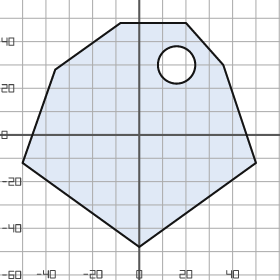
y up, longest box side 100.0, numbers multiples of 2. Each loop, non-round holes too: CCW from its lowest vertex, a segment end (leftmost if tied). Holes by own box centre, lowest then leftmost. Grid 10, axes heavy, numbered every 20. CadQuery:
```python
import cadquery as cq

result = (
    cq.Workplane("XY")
    .moveTo(0.0, -48.0)
    .lineTo(50.0, -12.0)
    .lineTo(36.0, 30.0)
    .lineTo(20.0, 48.0)
    .lineTo(-8.0, 48.0)
    .lineTo(-36.0, 28.0)
    .lineTo(-50.0, -12.0)
    .close()
    .moveTo(16.0, 30.0)
    .circle(8.0)
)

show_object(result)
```